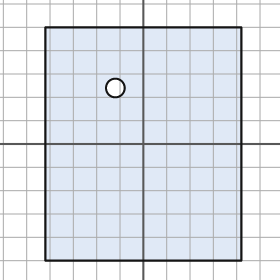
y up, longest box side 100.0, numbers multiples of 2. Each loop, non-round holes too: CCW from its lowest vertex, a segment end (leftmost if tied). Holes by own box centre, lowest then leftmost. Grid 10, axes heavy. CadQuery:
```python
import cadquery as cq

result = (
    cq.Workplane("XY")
    .moveTo(-42.0, -50.0)
    .lineTo(42.0, -50.0)
    .lineTo(42.0, 50.0)
    .lineTo(-42.0, 50.0)
    .close()
    .moveTo(-12.0, 24.0)
    .circle(4.0)
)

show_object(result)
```